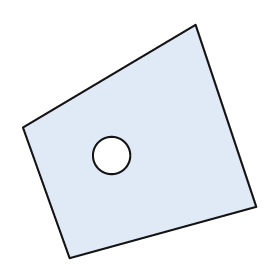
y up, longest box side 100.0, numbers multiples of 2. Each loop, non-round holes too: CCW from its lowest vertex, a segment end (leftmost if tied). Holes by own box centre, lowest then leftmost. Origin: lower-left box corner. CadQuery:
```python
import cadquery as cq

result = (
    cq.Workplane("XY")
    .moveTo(20.0, 0.0)
    .lineTo(100.0, 22.0)
    .lineTo(74.0, 100.0)
    .lineTo(0.0, 56.0)
    .close()
    .moveTo(38.0, 44.0)
    .circle(8.0)
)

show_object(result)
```